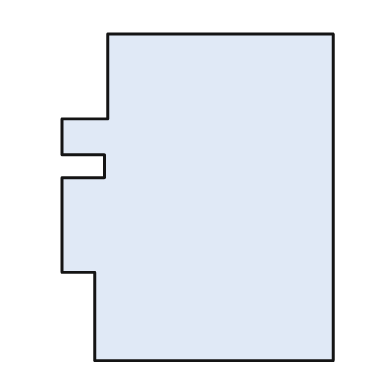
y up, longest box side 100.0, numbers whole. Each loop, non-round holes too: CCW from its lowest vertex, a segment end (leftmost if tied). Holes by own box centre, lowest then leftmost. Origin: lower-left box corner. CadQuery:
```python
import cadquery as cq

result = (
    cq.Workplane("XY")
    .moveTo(10.0, 0.0)
    .lineTo(83.0, 0.0)
    .lineTo(83.0, 100.0)
    .lineTo(14.0, 100.0)
    .lineTo(14.0, 74.0)
    .lineTo(0.0, 74.0)
    .lineTo(0.0, 63.0)
    .lineTo(13.0, 63.0)
    .lineTo(13.0, 56.0)
    .lineTo(0.0, 56.0)
    .lineTo(0.0, 27.0)
    .lineTo(10.0, 27.0)
    .close()
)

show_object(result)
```